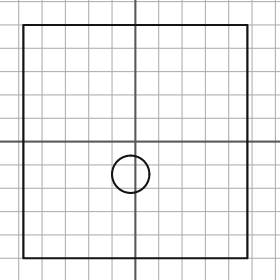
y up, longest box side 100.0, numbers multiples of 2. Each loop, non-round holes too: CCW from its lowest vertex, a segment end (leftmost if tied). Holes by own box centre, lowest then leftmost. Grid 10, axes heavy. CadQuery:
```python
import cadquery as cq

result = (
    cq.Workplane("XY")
    .moveTo(-48.0, -50.0)
    .lineTo(48.0, -50.0)
    .lineTo(48.0, 50.0)
    .lineTo(-48.0, 50.0)
    .close()
    .moveTo(-2.0, -14.0)
    .circle(8.0)
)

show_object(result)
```